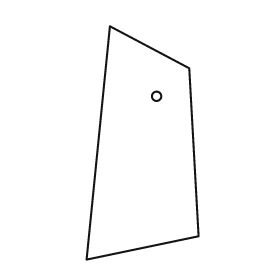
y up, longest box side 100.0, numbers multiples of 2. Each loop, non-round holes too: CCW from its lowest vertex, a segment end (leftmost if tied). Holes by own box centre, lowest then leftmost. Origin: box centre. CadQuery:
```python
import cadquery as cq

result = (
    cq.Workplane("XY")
    .moveTo(-24.0, -50.0)
    .lineTo(24.0, -40.0)
    .lineTo(20.0, 32.0)
    .lineTo(-14.0, 50.0)
    .close()
    .moveTo(6.0, 20.0)
    .circle(2.0)
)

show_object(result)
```